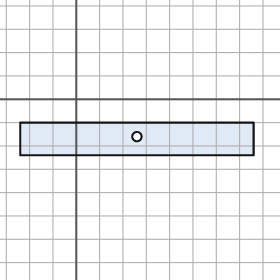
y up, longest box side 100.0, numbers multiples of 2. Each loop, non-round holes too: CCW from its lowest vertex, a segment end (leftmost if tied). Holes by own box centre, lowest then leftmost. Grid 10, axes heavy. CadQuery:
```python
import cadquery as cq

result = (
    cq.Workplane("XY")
    .moveTo(-24.0, -24.0)
    .lineTo(76.0, -24.0)
    .lineTo(76.0, -10.0)
    .lineTo(-24.0, -10.0)
    .close()
    .moveTo(26.0, -16.0)
    .circle(2.0)
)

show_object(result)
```